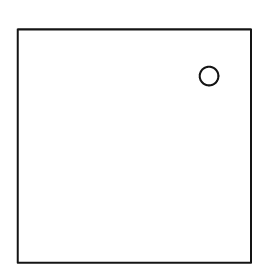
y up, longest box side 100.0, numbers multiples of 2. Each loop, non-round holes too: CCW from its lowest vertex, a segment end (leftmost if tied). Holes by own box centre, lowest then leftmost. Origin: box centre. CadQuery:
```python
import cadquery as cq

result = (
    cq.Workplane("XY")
    .moveTo(-50.0, -50.0)
    .lineTo(50.0, -50.0)
    .lineTo(50.0, 50.0)
    .lineTo(-50.0, 50.0)
    .close()
    .moveTo(32.0, 30.0)
    .circle(4.0)
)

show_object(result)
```